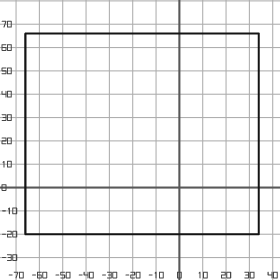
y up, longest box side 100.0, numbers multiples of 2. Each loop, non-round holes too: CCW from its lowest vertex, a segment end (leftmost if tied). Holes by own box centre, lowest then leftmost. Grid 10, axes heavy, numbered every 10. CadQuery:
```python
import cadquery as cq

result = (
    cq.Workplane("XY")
    .moveTo(-66.0, -20.0)
    .lineTo(34.0, -20.0)
    .lineTo(34.0, 66.0)
    .lineTo(-66.0, 66.0)
    .close()
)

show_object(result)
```